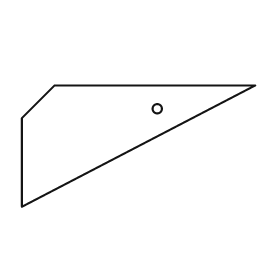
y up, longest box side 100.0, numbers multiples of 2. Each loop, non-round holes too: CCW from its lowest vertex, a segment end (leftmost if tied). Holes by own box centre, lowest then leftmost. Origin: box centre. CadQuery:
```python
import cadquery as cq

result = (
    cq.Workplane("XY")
    .moveTo(-50.0, -26.0)
    .lineTo(50.0, 26.0)
    .lineTo(-36.0, 26.0)
    .lineTo(-50.0, 12.0)
    .close()
    .moveTo(8.0, 16.0)
    .circle(2.0)
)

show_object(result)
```